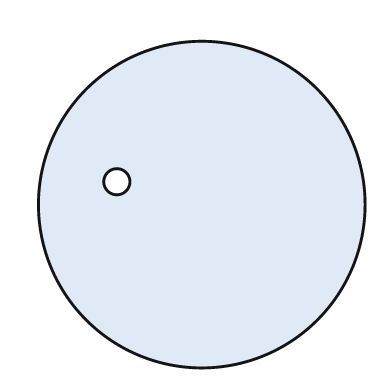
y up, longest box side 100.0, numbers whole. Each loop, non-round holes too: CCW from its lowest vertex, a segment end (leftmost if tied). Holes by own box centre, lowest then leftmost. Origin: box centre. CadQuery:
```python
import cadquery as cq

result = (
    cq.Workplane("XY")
    .moveTo(0.0, 0.0)
    .circle(50.0)
    .moveTo(-26.0, 7.0)
    .circle(4.0)
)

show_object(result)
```